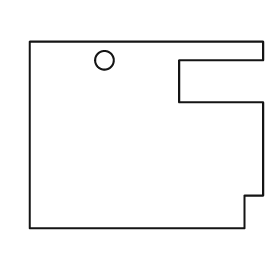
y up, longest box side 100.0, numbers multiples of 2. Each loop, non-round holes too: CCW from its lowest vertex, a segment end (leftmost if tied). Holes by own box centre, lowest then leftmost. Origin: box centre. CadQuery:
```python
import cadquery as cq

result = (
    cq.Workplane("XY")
    .moveTo(-50.0, -40.0)
    .lineTo(42.0, -40.0)
    .lineTo(42.0, -26.0)
    .lineTo(50.0, -26.0)
    .lineTo(50.0, 14.0)
    .lineTo(14.0, 14.0)
    .lineTo(14.0, 32.0)
    .lineTo(50.0, 32.0)
    .lineTo(50.0, 40.0)
    .lineTo(-50.0, 40.0)
    .close()
    .moveTo(-18.0, 32.0)
    .circle(4.0)
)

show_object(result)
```